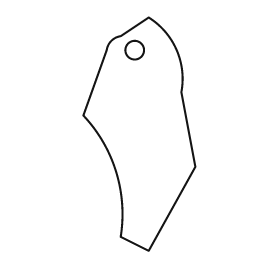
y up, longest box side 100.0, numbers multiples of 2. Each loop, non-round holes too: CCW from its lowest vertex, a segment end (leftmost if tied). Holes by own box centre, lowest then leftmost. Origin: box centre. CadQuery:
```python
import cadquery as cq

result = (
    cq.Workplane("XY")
    .moveTo(4.0, -50.0)
    .lineTo(24.0, -14.0)
    .lineTo(18.0, 18.0)
    .threePointArc((16.0, 36.0), (4.0, 50.0))
    .lineTo(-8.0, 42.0)
    .threePointArc((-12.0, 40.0), (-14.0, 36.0))
    .lineTo(-24.0, 8.0)
    .threePointArc((-10.0, -16.0), (-8.0, -44.0))
    .close()
    .moveTo(-2.0, 36.0)
    .circle(4.0)
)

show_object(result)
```